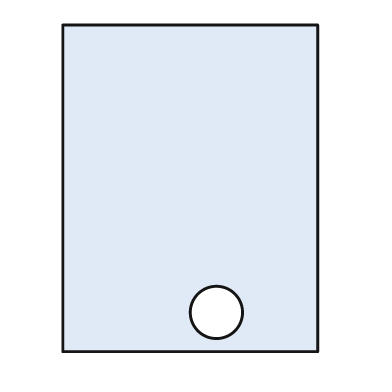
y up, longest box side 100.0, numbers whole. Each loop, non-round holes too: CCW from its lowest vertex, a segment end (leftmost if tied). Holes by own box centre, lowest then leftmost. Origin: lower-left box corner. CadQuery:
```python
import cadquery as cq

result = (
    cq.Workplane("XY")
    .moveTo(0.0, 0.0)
    .lineTo(78.0, 0.0)
    .lineTo(78.0, 100.0)
    .lineTo(0.0, 100.0)
    .close()
    .moveTo(47.0, 12.0)
    .circle(8.0)
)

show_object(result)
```